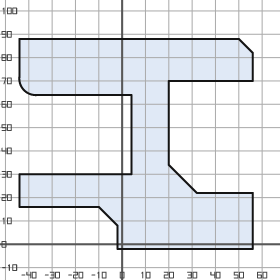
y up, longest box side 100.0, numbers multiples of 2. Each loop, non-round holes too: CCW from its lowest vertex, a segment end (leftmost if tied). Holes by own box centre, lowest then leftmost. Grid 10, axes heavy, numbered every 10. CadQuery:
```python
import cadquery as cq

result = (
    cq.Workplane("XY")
    .moveTo(-2.0, -2.0)
    .lineTo(56.0, -2.0)
    .lineTo(56.0, 22.0)
    .lineTo(32.0, 22.0)
    .lineTo(20.0, 34.0)
    .lineTo(20.0, 70.0)
    .lineTo(56.0, 70.0)
    .lineTo(56.0, 82.0)
    .lineTo(50.0, 88.0)
    .lineTo(-44.0, 88.0)
    .lineTo(-44.0, 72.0)
    .threePointArc((-42.0, 66.0), (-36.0, 64.0))
    .lineTo(4.0, 64.0)
    .lineTo(4.0, 30.0)
    .lineTo(-44.0, 30.0)
    .lineTo(-44.0, 16.0)
    .lineTo(-10.0, 16.0)
    .lineTo(-2.0, 8.0)
    .close()
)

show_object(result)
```